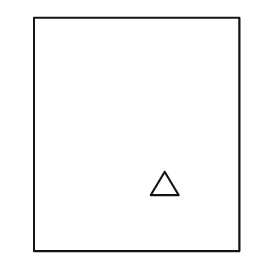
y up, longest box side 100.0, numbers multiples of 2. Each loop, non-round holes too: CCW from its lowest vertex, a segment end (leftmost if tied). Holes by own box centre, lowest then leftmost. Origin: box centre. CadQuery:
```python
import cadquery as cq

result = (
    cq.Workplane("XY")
    .moveTo(-44.0, -50.0)
    .lineTo(44.0, -50.0)
    .lineTo(44.0, 50.0)
    .lineTo(-44.0, 50.0)
    .close()
    .moveTo(6.0, -26.0)
    .lineTo(18.0, -26.0)
    .lineTo(12.0, -16.0)
    .close()
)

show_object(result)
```